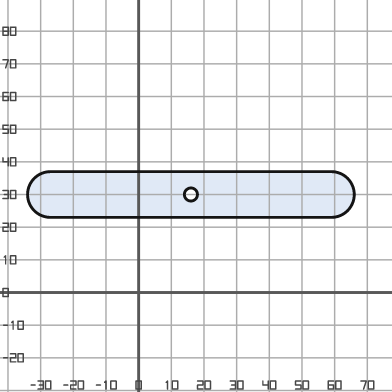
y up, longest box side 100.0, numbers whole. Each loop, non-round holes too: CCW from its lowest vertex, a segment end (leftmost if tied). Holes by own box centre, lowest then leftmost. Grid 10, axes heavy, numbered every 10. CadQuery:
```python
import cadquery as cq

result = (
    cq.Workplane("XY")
    .moveTo(-27.0, 23.0)
    .lineTo(59.0, 23.0)
    .threePointArc((66.0, 30.0), (59.0, 37.0))
    .lineTo(-27.0, 37.0)
    .threePointArc((-34.0, 30.0), (-27.0, 23.0))
    .close()
    .moveTo(16.0, 30.0)
    .circle(2.0)
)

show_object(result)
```